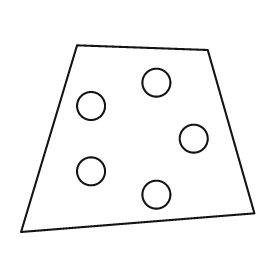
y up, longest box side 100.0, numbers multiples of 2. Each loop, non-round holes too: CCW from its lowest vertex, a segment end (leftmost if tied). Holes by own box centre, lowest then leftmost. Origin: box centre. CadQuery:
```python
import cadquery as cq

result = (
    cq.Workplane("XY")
    .moveTo(-50.0, -40.0)
    .lineTo(50.0, -32.0)
    .lineTo(30.0, 38.0)
    .lineTo(-26.0, 40.0)
    .close()
    .moveTo(8.0, -24.0)
    .circle(6.0)
    .moveTo(-20.0, -14.0)
    .circle(6.0)
    .moveTo(24.0, 0.0)
    .circle(6.0)
    .moveTo(-20.0, 14.0)
    .circle(6.0)
    .moveTo(8.0, 24.0)
    .circle(6.0)
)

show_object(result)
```